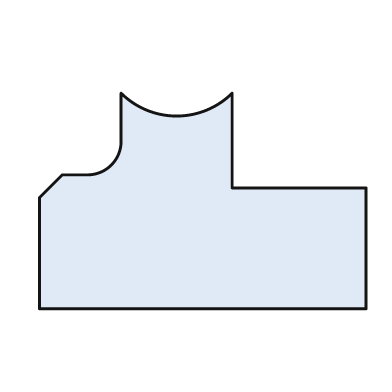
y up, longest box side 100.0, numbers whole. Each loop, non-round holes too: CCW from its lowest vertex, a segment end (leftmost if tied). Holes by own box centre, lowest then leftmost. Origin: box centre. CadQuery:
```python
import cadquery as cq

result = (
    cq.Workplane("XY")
    .moveTo(-50.0, -33.0)
    .lineTo(50.0, -33.0)
    .lineTo(50.0, 4.0)
    .lineTo(9.0, 4.0)
    .lineTo(9.0, 33.0)
    .threePointArc((-8.0, 26.0), (-25.0, 33.0))
    .lineTo(-25.0, 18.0)
    .threePointArc((-28.0, 11.0), (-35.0, 8.0))
    .lineTo(-43.0, 8.0)
    .lineTo(-50.0, 1.0)
    .close()
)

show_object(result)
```